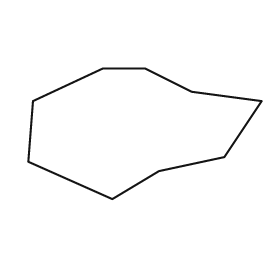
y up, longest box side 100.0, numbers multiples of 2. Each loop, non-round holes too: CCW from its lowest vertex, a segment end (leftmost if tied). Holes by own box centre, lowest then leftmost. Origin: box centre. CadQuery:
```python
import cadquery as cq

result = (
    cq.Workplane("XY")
    .moveTo(-14.0, -28.0)
    .lineTo(6.0, -16.0)
    .lineTo(34.0, -10.0)
    .lineTo(50.0, 14.0)
    .lineTo(20.0, 18.0)
    .lineTo(0.0, 28.0)
    .lineTo(-18.0, 28.0)
    .lineTo(-48.0, 14.0)
    .lineTo(-50.0, -12.0)
    .close()
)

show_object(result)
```